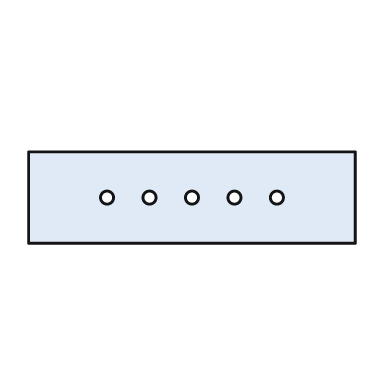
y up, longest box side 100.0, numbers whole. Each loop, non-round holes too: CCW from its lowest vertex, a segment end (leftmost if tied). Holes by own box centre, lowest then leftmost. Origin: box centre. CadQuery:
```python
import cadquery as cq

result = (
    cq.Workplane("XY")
    .moveTo(-50.0, -14.0)
    .lineTo(50.0, -14.0)
    .lineTo(50.0, 14.0)
    .lineTo(-50.0, 14.0)
    .close()
    .moveTo(-26.0, 0.0)
    .circle(2.0)
    .moveTo(-13.0, 0.0)
    .circle(2.0)
    .moveTo(0.0, 0.0)
    .circle(2.0)
    .moveTo(13.0, 0.0)
    .circle(2.0)
    .moveTo(26.0, 0.0)
    .circle(2.0)
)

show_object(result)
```